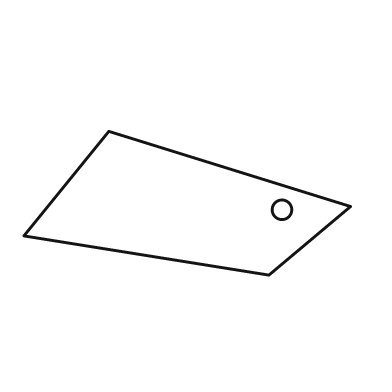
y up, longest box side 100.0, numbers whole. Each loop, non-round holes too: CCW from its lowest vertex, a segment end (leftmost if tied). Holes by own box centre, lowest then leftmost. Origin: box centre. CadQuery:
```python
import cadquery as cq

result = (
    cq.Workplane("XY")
    .moveTo(25.0, -22.0)
    .lineTo(50.0, -1.0)
    .lineTo(-24.0, 22.0)
    .lineTo(-50.0, -10.0)
    .close()
    .moveTo(29.0, -2.0)
    .circle(3.0)
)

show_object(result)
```